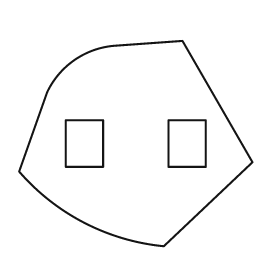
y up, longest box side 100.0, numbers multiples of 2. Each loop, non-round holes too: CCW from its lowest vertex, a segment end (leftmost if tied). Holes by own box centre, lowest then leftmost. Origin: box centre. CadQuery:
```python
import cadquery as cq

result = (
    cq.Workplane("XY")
    .moveTo(12.0, -44.0)
    .lineTo(50.0, -8.0)
    .lineTo(20.0, 44.0)
    .lineTo(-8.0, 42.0)
    .threePointArc((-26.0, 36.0), (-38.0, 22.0))
    .lineTo(-50.0, -12.0)
    .threePointArc((-22.0, -34.0), (12.0, -44.0))
    .close()
    .moveTo(-30.0, -10.0)
    .lineTo(-14.0, -10.0)
    .lineTo(-14.0, 10.0)
    .lineTo(-30.0, 10.0)
    .close()
    .moveTo(14.0, -10.0)
    .lineTo(30.0, -10.0)
    .lineTo(30.0, 10.0)
    .lineTo(14.0, 10.0)
    .close()
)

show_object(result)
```